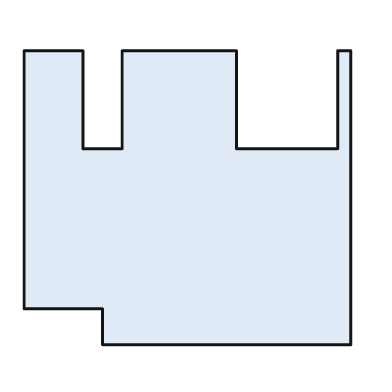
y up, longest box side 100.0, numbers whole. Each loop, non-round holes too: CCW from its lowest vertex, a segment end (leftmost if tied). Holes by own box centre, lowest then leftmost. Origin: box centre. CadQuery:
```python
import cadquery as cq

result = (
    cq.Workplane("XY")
    .moveTo(-26.0, -45.0)
    .lineTo(50.0, -45.0)
    .lineTo(50.0, 45.0)
    .lineTo(46.0, 45.0)
    .lineTo(46.0, 15.0)
    .lineTo(15.0, 15.0)
    .lineTo(15.0, 45.0)
    .lineTo(-20.0, 45.0)
    .lineTo(-20.0, 15.0)
    .lineTo(-32.0, 15.0)
    .lineTo(-32.0, 45.0)
    .lineTo(-50.0, 45.0)
    .lineTo(-50.0, -34.0)
    .lineTo(-26.0, -34.0)
    .close()
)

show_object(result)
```